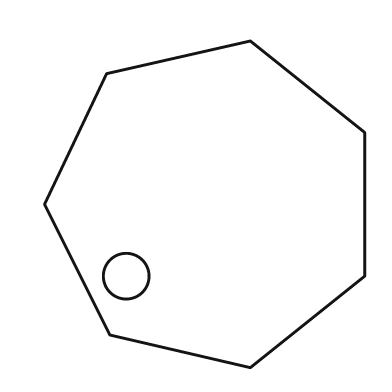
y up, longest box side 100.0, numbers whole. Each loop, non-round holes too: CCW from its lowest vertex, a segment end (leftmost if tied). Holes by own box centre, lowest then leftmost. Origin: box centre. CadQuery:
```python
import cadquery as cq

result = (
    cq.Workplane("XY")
    .moveTo(14.0, -50.0)
    .lineTo(49.0, -22.0)
    .lineTo(49.0, 22.0)
    .lineTo(14.0, 50.0)
    .lineTo(-30.0, 40.0)
    .lineTo(-49.0, 0.0)
    .lineTo(-29.0, -40.0)
    .close()
    .moveTo(-24.0, -22.0)
    .circle(7.0)
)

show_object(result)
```